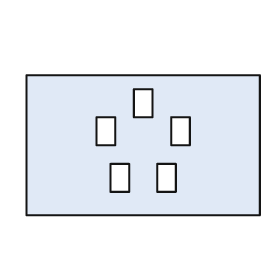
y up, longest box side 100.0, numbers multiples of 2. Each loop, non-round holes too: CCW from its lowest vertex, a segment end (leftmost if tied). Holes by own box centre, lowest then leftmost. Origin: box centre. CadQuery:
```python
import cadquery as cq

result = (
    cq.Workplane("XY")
    .moveTo(-50.0, -30.0)
    .lineTo(50.0, -30.0)
    .lineTo(50.0, 30.0)
    .lineTo(-50.0, 30.0)
    .close()
    .moveTo(-14.0, -20.0)
    .lineTo(-6.0, -20.0)
    .lineTo(-6.0, -8.0)
    .lineTo(-14.0, -8.0)
    .close()
    .moveTo(6.0, -20.0)
    .lineTo(14.0, -20.0)
    .lineTo(14.0, -8.0)
    .lineTo(6.0, -8.0)
    .close()
    .moveTo(-20.0, 0.0)
    .lineTo(-12.0, 0.0)
    .lineTo(-12.0, 12.0)
    .lineTo(-20.0, 12.0)
    .close()
    .moveTo(12.0, 0.0)
    .lineTo(20.0, 0.0)
    .lineTo(20.0, 12.0)
    .lineTo(12.0, 12.0)
    .close()
    .moveTo(-4.0, 12.0)
    .lineTo(4.0, 12.0)
    .lineTo(4.0, 24.0)
    .lineTo(-4.0, 24.0)
    .close()
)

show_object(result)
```